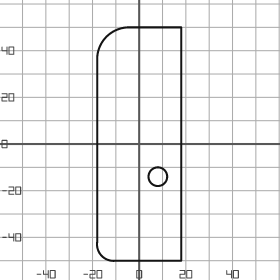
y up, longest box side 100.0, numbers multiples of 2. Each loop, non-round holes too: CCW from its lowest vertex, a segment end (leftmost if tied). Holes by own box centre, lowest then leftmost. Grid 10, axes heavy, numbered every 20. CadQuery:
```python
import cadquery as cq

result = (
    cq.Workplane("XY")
    .moveTo(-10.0, -50.0)
    .lineTo(18.0, -50.0)
    .lineTo(18.0, 50.0)
    .lineTo(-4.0, 50.0)
    .threePointArc((-14.0, 46.0), (-18.0, 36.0))
    .lineTo(-18.0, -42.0)
    .threePointArc((-16.0, -48.0), (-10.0, -50.0))
    .close()
    .moveTo(8.0, -14.0)
    .circle(4.0)
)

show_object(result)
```